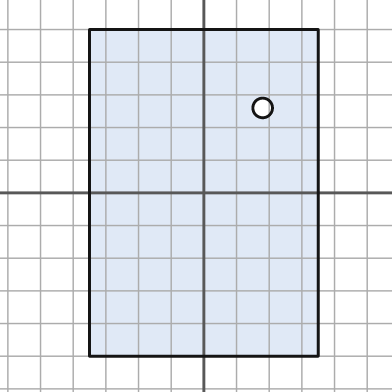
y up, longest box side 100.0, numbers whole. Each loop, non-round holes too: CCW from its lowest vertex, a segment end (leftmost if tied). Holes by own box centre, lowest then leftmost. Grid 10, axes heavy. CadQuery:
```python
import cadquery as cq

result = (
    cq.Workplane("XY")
    .moveTo(-35.0, -50.0)
    .lineTo(35.0, -50.0)
    .lineTo(35.0, 50.0)
    .lineTo(-35.0, 50.0)
    .close()
    .moveTo(18.0, 26.0)
    .circle(3.0)
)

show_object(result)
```